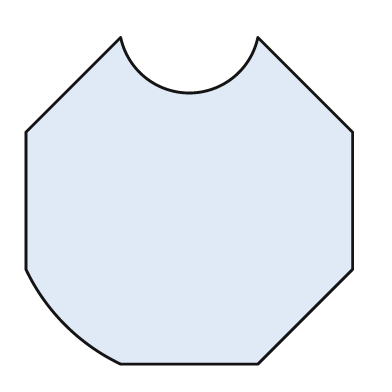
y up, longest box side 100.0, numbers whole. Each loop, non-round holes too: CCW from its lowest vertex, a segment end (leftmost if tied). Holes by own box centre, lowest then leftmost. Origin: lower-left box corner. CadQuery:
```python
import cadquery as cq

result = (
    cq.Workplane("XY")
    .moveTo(29.0, 0.0)
    .lineTo(71.0, 0.0)
    .lineTo(100.0, 29.0)
    .lineTo(100.0, 71.0)
    .lineTo(71.0, 100.0)
    .threePointArc((50.0, 83.0), (29.0, 100.0))
    .lineTo(0.0, 71.0)
    .lineTo(0.0, 29.0)
    .threePointArc((12.0, 12.0), (29.0, 0.0))
    .close()
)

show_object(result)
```